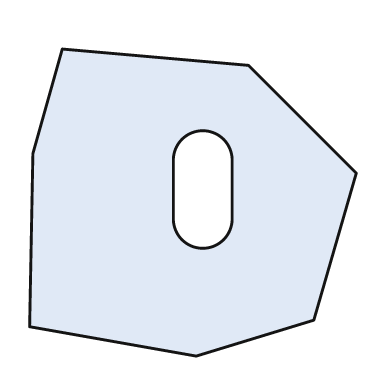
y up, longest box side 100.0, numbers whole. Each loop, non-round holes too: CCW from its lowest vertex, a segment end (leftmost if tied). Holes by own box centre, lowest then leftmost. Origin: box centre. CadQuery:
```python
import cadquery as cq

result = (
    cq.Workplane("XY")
    .moveTo(1.0, -47.0)
    .lineTo(37.0, -36.0)
    .lineTo(50.0, 9.0)
    .lineTo(17.0, 42.0)
    .lineTo(-40.0, 47.0)
    .lineTo(-49.0, 15.0)
    .lineTo(-50.0, -38.0)
    .close()
    .moveTo(-6.0, -5.0)
    .threePointArc((3.0, -14.0), (12.0, -5.0))
    .lineTo(12.0, 13.0)
    .threePointArc((3.0, 22.0), (-6.0, 13.0))
    .close()
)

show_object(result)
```